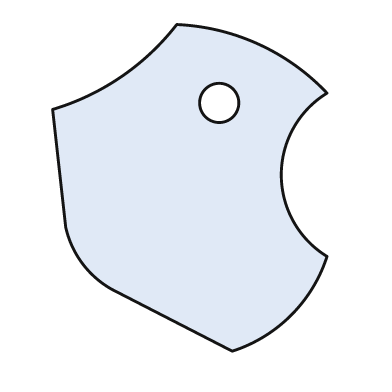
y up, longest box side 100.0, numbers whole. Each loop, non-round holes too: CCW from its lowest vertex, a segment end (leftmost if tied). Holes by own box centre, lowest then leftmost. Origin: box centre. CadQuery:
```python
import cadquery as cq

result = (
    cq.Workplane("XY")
    .moveTo(13.0, -50.0)
    .threePointArc((31.0, -39.0), (42.0, -21.0))
    .threePointArc((28.0, 4.0), (42.0, 29.0))
    .threePointArc((21.0, 44.0), (-4.0, 50.0))
    .threePointArc((-21.0, 34.0), (-42.0, 24.0))
    .lineTo(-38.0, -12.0)
    .threePointArc((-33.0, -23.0), (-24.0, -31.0))
    .close()
    .moveTo(9.0, 26.0)
    .circle(6.0)
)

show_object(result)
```